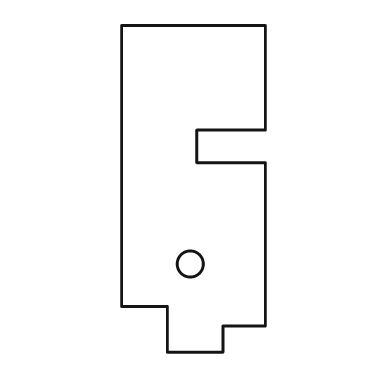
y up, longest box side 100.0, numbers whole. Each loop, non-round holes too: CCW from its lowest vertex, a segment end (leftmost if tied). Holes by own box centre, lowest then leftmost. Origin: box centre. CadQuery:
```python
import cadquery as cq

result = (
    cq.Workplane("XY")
    .moveTo(-8.0, -50.0)
    .lineTo(9.0, -50.0)
    .lineTo(9.0, -42.0)
    .lineTo(22.0, -42.0)
    .lineTo(22.0, 8.0)
    .lineTo(1.0, 8.0)
    .lineTo(1.0, 18.0)
    .lineTo(22.0, 18.0)
    .lineTo(22.0, 50.0)
    .lineTo(-22.0, 50.0)
    .lineTo(-22.0, -36.0)
    .lineTo(-8.0, -36.0)
    .close()
    .moveTo(-1.0, -23.0)
    .circle(4.0)
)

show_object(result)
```